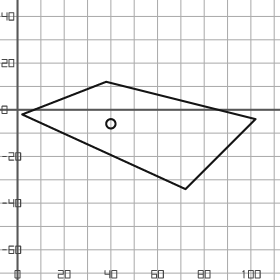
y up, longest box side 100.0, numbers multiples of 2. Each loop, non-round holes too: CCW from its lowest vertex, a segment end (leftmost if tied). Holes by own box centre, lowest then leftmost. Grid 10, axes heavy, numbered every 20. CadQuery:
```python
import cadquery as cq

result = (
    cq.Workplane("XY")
    .moveTo(72.0, -34.0)
    .lineTo(102.0, -4.0)
    .lineTo(38.0, 12.0)
    .lineTo(2.0, -2.0)
    .close()
    .moveTo(40.0, -6.0)
    .circle(2.0)
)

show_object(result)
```